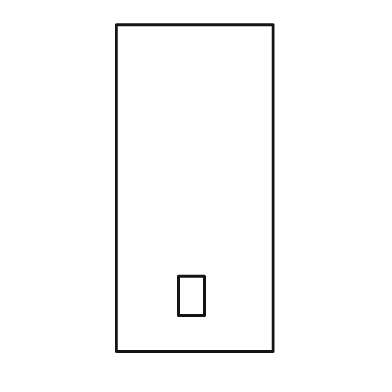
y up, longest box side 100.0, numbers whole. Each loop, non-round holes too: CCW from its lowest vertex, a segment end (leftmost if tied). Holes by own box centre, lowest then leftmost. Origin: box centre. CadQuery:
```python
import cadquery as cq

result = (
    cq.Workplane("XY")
    .moveTo(-24.0, -50.0)
    .lineTo(24.0, -50.0)
    .lineTo(24.0, 50.0)
    .lineTo(-24.0, 50.0)
    .close()
    .moveTo(-5.0, -39.0)
    .lineTo(3.0, -39.0)
    .lineTo(3.0, -27.0)
    .lineTo(-5.0, -27.0)
    .close()
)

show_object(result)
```